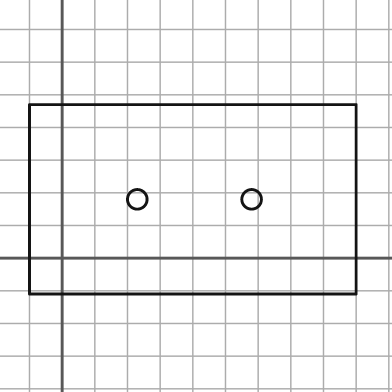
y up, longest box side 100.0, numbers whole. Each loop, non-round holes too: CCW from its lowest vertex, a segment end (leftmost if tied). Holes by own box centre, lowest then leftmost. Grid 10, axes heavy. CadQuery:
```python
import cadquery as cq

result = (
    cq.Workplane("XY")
    .moveTo(-10.0, -11.0)
    .lineTo(90.0, -11.0)
    .lineTo(90.0, 47.0)
    .lineTo(-10.0, 47.0)
    .close()
    .moveTo(23.0, 18.0)
    .circle(3.0)
    .moveTo(58.0, 18.0)
    .circle(3.0)
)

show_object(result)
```